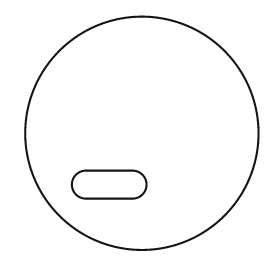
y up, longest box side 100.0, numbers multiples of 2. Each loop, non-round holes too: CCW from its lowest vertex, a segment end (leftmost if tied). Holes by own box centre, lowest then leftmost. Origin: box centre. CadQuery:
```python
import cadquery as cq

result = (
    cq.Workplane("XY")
    .moveTo(0.0, 0.0)
    .circle(50.0)
    .moveTo(-24.0, -28.0)
    .lineTo(-4.0, -28.0)
    .threePointArc((2.0, -22.0), (-4.0, -16.0))
    .lineTo(-24.0, -16.0)
    .threePointArc((-30.0, -22.0), (-24.0, -28.0))
    .close()
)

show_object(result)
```